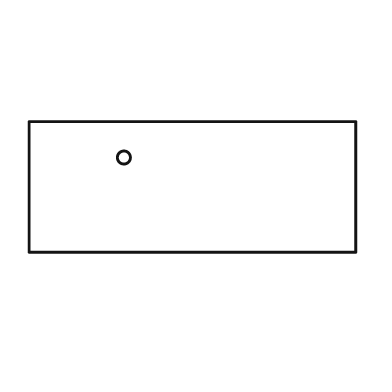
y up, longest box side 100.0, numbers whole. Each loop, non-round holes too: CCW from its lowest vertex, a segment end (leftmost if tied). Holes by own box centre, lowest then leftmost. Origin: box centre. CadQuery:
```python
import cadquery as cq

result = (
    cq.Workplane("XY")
    .moveTo(-50.0, -20.0)
    .lineTo(50.0, -20.0)
    .lineTo(50.0, 20.0)
    .lineTo(-50.0, 20.0)
    .close()
    .moveTo(-21.0, 9.0)
    .circle(2.0)
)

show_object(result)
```